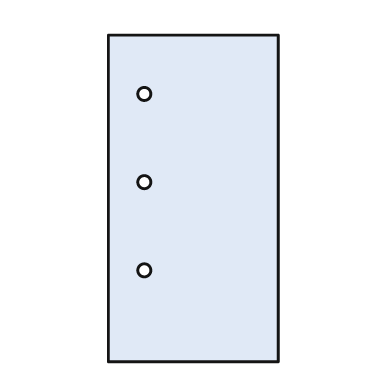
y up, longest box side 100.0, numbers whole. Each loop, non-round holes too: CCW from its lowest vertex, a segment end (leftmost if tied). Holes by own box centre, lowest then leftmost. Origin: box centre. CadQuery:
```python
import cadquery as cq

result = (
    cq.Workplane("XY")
    .moveTo(-26.0, -50.0)
    .lineTo(26.0, -50.0)
    .lineTo(26.0, 50.0)
    .lineTo(-26.0, 50.0)
    .close()
    .moveTo(-15.0, -22.0)
    .circle(2.0)
    .moveTo(-15.0, 5.0)
    .circle(2.0)
    .moveTo(-15.0, 32.0)
    .circle(2.0)
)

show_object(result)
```